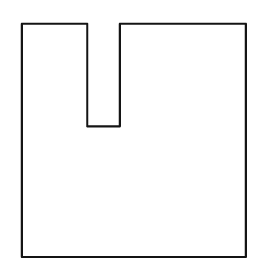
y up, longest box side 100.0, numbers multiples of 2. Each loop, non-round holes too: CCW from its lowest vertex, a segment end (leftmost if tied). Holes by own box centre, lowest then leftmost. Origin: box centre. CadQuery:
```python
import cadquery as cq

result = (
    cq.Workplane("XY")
    .moveTo(-48.0, -50.0)
    .lineTo(48.0, -50.0)
    .lineTo(48.0, 50.0)
    .lineTo(-6.0, 50.0)
    .lineTo(-6.0, 6.0)
    .lineTo(-20.0, 6.0)
    .lineTo(-20.0, 50.0)
    .lineTo(-48.0, 50.0)
    .close()
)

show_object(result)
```